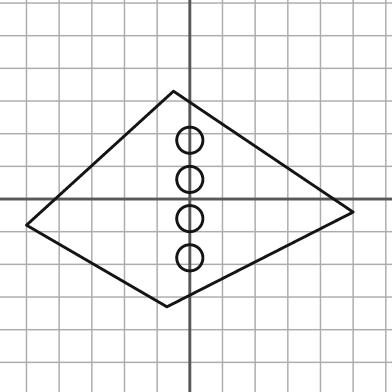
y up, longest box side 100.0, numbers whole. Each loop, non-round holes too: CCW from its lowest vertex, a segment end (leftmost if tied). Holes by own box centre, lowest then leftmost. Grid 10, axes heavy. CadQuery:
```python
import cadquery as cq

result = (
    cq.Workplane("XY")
    .moveTo(-7.0, -33.0)
    .lineTo(50.0, -4.0)
    .lineTo(-5.0, 33.0)
    .lineTo(-50.0, -8.0)
    .close()
    .moveTo(0.0, -18.0)
    .circle(4.0)
    .moveTo(0.0, -6.0)
    .circle(4.0)
    .moveTo(0.0, 6.0)
    .circle(4.0)
    .moveTo(0.0, 18.0)
    .circle(4.0)
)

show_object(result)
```